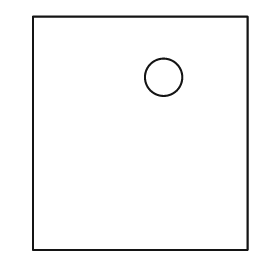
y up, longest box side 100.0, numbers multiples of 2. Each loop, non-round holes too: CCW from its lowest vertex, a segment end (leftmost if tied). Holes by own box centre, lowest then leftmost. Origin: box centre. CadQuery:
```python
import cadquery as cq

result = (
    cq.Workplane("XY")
    .moveTo(-46.0, -50.0)
    .lineTo(46.0, -50.0)
    .lineTo(46.0, 50.0)
    .lineTo(-46.0, 50.0)
    .close()
    .moveTo(10.0, 24.0)
    .circle(8.0)
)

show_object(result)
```